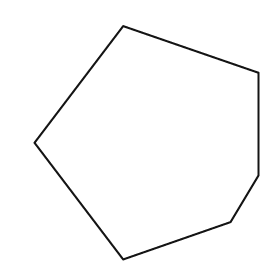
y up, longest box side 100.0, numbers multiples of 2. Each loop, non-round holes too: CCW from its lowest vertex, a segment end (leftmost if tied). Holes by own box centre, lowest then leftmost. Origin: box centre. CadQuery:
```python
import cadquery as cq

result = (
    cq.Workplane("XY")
    .moveTo(-10.0, -50.0)
    .lineTo(36.0, -34.0)
    .lineTo(48.0, -14.0)
    .lineTo(48.0, 30.0)
    .lineTo(-10.0, 50.0)
    .lineTo(-48.0, 0.0)
    .close()
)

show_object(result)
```